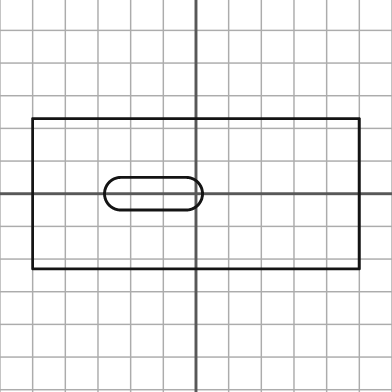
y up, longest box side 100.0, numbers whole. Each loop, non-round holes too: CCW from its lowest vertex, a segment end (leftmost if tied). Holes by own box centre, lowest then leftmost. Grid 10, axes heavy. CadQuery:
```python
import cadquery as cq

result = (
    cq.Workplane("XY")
    .moveTo(-50.0, -23.0)
    .lineTo(50.0, -23.0)
    .lineTo(50.0, 23.0)
    .lineTo(-50.0, 23.0)
    .close()
    .moveTo(-23.0, -5.0)
    .lineTo(-3.0, -5.0)
    .threePointArc((2.0, 0.0), (-3.0, 5.0))
    .lineTo(-23.0, 5.0)
    .threePointArc((-28.0, 0.0), (-23.0, -5.0))
    .close()
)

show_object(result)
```